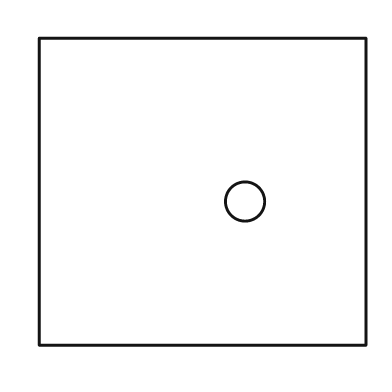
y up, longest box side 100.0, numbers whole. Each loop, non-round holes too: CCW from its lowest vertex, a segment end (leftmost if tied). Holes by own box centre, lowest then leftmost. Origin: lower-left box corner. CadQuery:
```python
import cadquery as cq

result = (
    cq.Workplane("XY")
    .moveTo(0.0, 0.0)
    .lineTo(100.0, 0.0)
    .lineTo(100.0, 94.0)
    .lineTo(0.0, 94.0)
    .close()
    .moveTo(63.0, 44.0)
    .circle(6.0)
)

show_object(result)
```